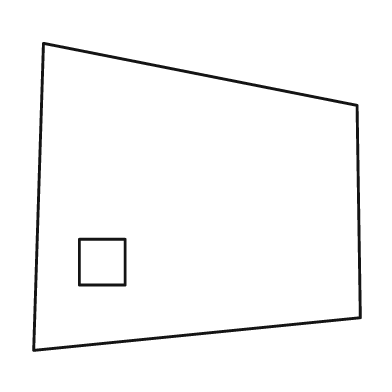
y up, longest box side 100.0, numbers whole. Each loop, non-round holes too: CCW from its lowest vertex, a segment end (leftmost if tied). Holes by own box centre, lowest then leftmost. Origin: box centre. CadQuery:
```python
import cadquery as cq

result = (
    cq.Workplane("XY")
    .moveTo(-50.0, -47.0)
    .lineTo(50.0, -37.0)
    .lineTo(49.0, 28.0)
    .lineTo(-47.0, 47.0)
    .close()
    .moveTo(-36.0, -27.0)
    .lineTo(-22.0, -27.0)
    .lineTo(-22.0, -13.0)
    .lineTo(-36.0, -13.0)
    .close()
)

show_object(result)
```